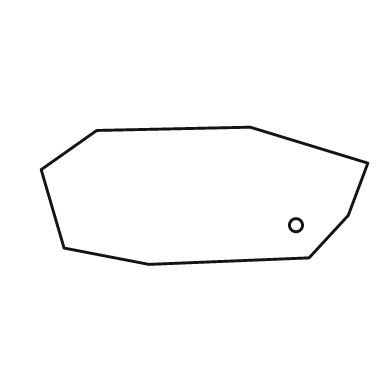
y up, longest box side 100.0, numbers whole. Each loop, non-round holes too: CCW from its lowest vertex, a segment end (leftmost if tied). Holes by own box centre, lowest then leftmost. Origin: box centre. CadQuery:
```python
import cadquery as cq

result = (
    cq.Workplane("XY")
    .moveTo(-17.0, -21.0)
    .lineTo(32.0, -19.0)
    .lineTo(44.0, -6.0)
    .lineTo(50.0, 10.0)
    .lineTo(14.0, 21.0)
    .lineTo(-33.0, 20.0)
    .lineTo(-50.0, 8.0)
    .lineTo(-43.0, -16.0)
    .close()
    .moveTo(28.0, -9.0)
    .circle(2.0)
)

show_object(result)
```